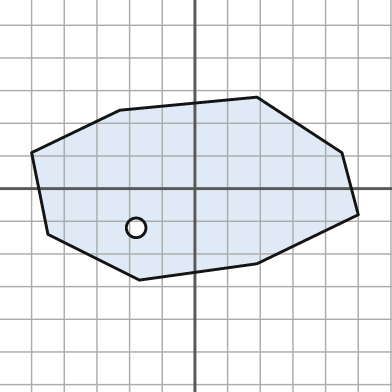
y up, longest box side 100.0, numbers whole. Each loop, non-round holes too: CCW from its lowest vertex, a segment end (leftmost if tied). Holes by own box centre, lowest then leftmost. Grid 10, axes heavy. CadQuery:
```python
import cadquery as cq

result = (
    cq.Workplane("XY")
    .moveTo(-17.0, -28.0)
    .lineTo(19.0, -23.0)
    .lineTo(50.0, -8.0)
    .lineTo(45.0, 11.0)
    .lineTo(19.0, 28.0)
    .lineTo(-23.0, 24.0)
    .lineTo(-50.0, 11.0)
    .lineTo(-45.0, -14.0)
    .close()
    .moveTo(-18.0, -12.0)
    .circle(3.0)
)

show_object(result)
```